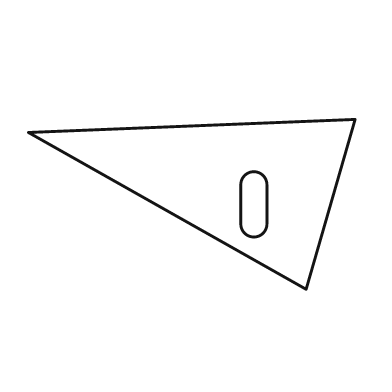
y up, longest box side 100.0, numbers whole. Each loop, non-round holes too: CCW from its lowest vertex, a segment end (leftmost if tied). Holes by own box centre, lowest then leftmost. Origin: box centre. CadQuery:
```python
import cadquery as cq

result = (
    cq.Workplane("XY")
    .moveTo(35.0, -26.0)
    .lineTo(50.0, 26.0)
    .lineTo(-50.0, 22.0)
    .close()
    .moveTo(15.0, -6.0)
    .threePointArc((19.0, -10.0), (23.0, -6.0))
    .lineTo(23.0, 6.0)
    .threePointArc((19.0, 10.0), (15.0, 6.0))
    .close()
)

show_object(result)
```